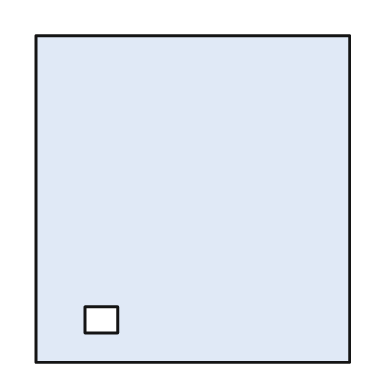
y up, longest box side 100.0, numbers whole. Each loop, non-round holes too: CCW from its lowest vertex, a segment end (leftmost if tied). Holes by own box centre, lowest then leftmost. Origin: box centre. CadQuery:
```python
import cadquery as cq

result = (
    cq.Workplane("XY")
    .moveTo(-48.0, -50.0)
    .lineTo(48.0, -50.0)
    .lineTo(48.0, 50.0)
    .lineTo(-48.0, 50.0)
    .close()
    .moveTo(-33.0, -41.0)
    .lineTo(-23.0, -41.0)
    .lineTo(-23.0, -33.0)
    .lineTo(-33.0, -33.0)
    .close()
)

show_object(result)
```